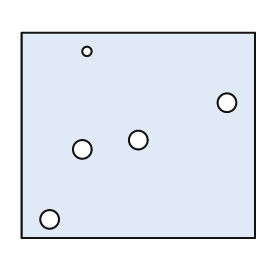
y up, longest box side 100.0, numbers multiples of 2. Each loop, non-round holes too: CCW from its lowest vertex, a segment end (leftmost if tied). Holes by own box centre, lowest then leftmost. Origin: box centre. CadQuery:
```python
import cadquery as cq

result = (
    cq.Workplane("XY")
    .moveTo(-50.0, -44.0)
    .lineTo(50.0, -44.0)
    .lineTo(50.0, 44.0)
    .lineTo(-50.0, 44.0)
    .close()
    .moveTo(-38.0, -36.0)
    .circle(4.0)
    .moveTo(-24.0, -6.0)
    .circle(4.0)
    .moveTo(0.0, -2.0)
    .circle(4.0)
    .moveTo(38.0, 14.0)
    .circle(4.0)
    .moveTo(-22.0, 36.0)
    .circle(2.0)
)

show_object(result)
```